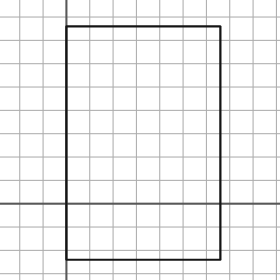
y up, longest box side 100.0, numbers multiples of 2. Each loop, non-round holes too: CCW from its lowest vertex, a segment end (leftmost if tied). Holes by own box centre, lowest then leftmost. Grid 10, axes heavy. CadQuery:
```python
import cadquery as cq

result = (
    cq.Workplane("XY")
    .moveTo(0.0, -24.0)
    .lineTo(66.0, -24.0)
    .lineTo(66.0, 76.0)
    .lineTo(0.0, 76.0)
    .close()
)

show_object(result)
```